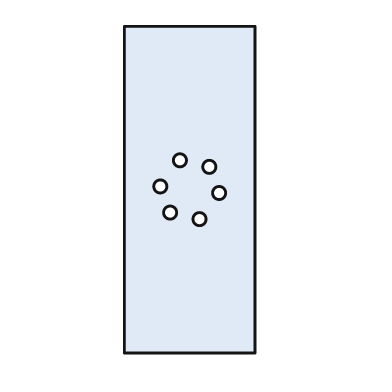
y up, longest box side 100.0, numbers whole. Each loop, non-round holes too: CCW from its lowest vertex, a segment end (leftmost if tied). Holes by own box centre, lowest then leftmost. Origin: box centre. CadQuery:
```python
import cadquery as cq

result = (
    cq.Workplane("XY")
    .moveTo(-20.0, -50.0)
    .lineTo(20.0, -50.0)
    .lineTo(20.0, 50.0)
    .lineTo(-20.0, 50.0)
    .close()
    .moveTo(3.0, -9.0)
    .circle(2.0)
    .moveTo(-6.0, -7.0)
    .circle(2.0)
    .moveTo(9.0, -1.0)
    .circle(2.0)
    .moveTo(-9.0, 1.0)
    .circle(2.0)
    .moveTo(6.0, 7.0)
    .circle(2.0)
    .moveTo(-3.0, 9.0)
    .circle(2.0)
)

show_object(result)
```